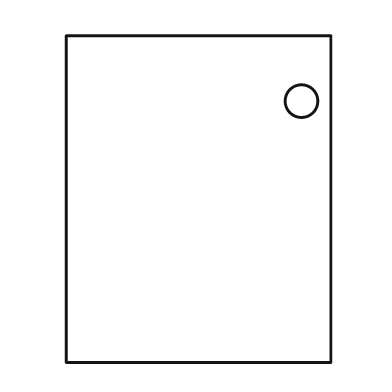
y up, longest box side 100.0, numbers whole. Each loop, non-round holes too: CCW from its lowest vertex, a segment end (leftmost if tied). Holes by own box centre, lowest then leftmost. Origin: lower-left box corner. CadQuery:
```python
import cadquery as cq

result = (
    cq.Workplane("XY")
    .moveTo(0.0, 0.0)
    .lineTo(81.0, 0.0)
    .lineTo(81.0, 100.0)
    .lineTo(0.0, 100.0)
    .close()
    .moveTo(72.0, 80.0)
    .circle(5.0)
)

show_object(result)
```